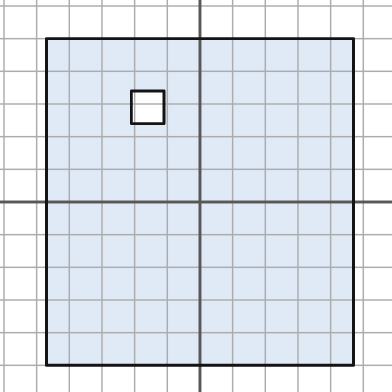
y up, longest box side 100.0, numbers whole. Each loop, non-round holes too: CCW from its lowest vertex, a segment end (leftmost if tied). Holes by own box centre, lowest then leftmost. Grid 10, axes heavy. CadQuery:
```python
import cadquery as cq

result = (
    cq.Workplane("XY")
    .moveTo(-47.0, -50.0)
    .lineTo(47.0, -50.0)
    .lineTo(47.0, 50.0)
    .lineTo(-47.0, 50.0)
    .close()
    .moveTo(-21.0, 24.0)
    .lineTo(-11.0, 24.0)
    .lineTo(-11.0, 34.0)
    .lineTo(-21.0, 34.0)
    .close()
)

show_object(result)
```